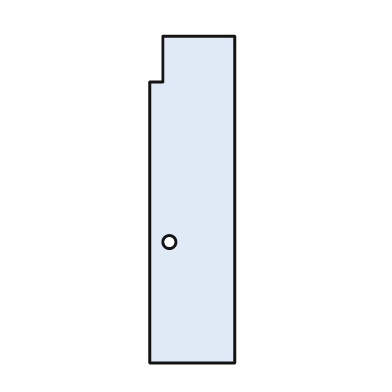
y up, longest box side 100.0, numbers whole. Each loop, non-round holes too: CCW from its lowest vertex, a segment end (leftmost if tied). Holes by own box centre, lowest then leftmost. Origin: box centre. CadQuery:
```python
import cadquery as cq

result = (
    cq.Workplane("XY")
    .moveTo(-13.0, -50.0)
    .lineTo(13.0, -50.0)
    .lineTo(13.0, 50.0)
    .lineTo(-9.0, 50.0)
    .lineTo(-9.0, 36.0)
    .lineTo(-13.0, 36.0)
    .close()
    .moveTo(-7.0, -13.0)
    .circle(2.0)
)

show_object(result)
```